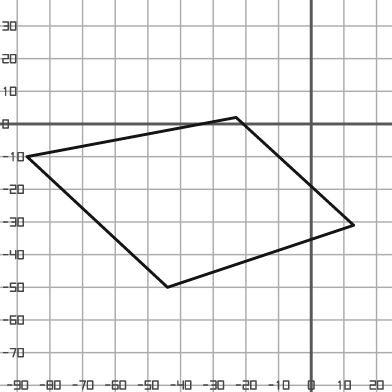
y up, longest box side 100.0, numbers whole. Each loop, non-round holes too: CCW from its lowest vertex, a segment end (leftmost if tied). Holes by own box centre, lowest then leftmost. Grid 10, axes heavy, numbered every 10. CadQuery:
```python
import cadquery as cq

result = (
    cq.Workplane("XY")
    .moveTo(-44.0, -50.0)
    .lineTo(13.0, -31.0)
    .lineTo(-23.0, 2.0)
    .lineTo(-87.0, -10.0)
    .close()
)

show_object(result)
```